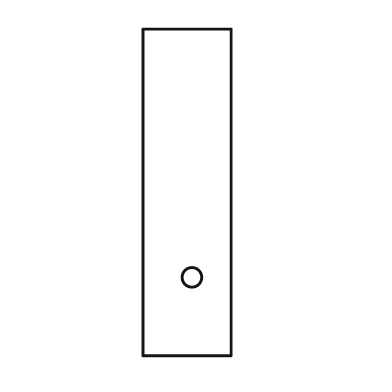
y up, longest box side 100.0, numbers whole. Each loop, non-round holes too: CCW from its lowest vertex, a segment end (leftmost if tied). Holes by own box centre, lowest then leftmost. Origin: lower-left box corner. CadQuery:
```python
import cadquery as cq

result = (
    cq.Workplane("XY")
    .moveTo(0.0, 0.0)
    .lineTo(27.0, 0.0)
    .lineTo(27.0, 100.0)
    .lineTo(0.0, 100.0)
    .close()
    .moveTo(15.0, 24.0)
    .circle(3.0)
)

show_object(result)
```